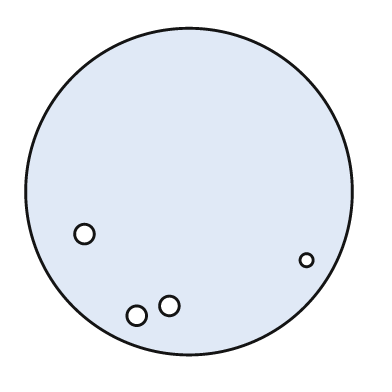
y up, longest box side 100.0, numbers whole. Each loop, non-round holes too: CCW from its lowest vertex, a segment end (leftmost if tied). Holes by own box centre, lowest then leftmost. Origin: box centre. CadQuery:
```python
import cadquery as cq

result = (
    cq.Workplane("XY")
    .moveTo(0.0, 0.0)
    .circle(50.0)
    .moveTo(-16.0, -38.0)
    .circle(3.0)
    .moveTo(-6.0, -35.0)
    .circle(3.0)
    .moveTo(36.0, -21.0)
    .circle(2.0)
    .moveTo(-32.0, -13.0)
    .circle(3.0)
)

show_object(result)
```